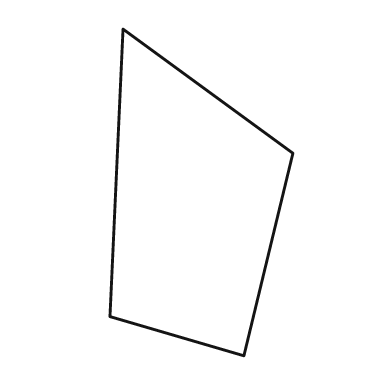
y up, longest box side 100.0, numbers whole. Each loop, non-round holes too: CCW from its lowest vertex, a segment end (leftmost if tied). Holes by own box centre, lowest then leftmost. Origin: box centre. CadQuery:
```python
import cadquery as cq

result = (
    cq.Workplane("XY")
    .moveTo(13.0, -50.0)
    .lineTo(28.0, 12.0)
    .lineTo(-24.0, 50.0)
    .lineTo(-28.0, -38.0)
    .close()
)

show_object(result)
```